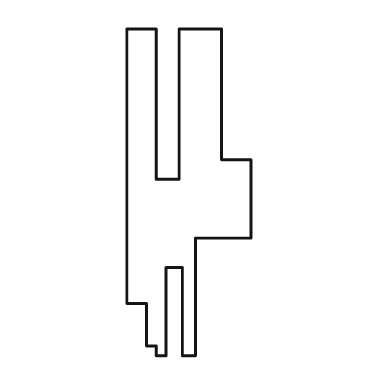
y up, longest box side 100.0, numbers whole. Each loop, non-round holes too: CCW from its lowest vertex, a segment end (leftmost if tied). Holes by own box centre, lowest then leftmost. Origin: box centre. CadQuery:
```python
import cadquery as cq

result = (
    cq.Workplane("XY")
    .moveTo(-10.0, -50.0)
    .lineTo(-7.0, -50.0)
    .lineTo(-7.0, -23.0)
    .lineTo(-2.0, -23.0)
    .lineTo(-2.0, -50.0)
    .lineTo(2.0, -50.0)
    .lineTo(2.0, -14.0)
    .lineTo(19.0, -14.0)
    .lineTo(19.0, 10.0)
    .lineTo(10.0, 10.0)
    .lineTo(10.0, 50.0)
    .lineTo(-3.0, 50.0)
    .lineTo(-3.0, 4.0)
    .lineTo(-10.0, 4.0)
    .lineTo(-10.0, 50.0)
    .lineTo(-19.0, 50.0)
    .lineTo(-19.0, -34.0)
    .lineTo(-13.0, -34.0)
    .lineTo(-13.0, -47.0)
    .lineTo(-10.0, -47.0)
    .close()
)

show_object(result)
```